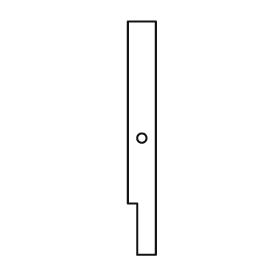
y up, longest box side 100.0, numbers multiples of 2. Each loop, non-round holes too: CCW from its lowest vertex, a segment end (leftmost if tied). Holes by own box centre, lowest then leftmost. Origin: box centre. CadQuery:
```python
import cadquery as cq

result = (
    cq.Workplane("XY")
    .moveTo(-2.0, -50.0)
    .lineTo(6.0, -50.0)
    .lineTo(6.0, 50.0)
    .lineTo(-6.0, 50.0)
    .lineTo(-6.0, -28.0)
    .lineTo(-2.0, -28.0)
    .close()
    .moveTo(0.0, 0.0)
    .circle(2.0)
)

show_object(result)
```